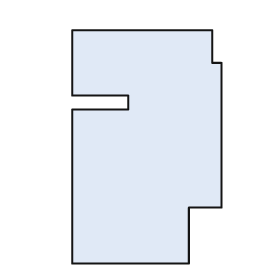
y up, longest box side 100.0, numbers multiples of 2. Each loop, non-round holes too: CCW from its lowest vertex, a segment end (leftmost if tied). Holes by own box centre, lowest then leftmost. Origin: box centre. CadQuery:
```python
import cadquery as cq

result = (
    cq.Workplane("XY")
    .moveTo(-32.0, -50.0)
    .lineTo(18.0, -50.0)
    .lineTo(18.0, -26.0)
    .lineTo(32.0, -26.0)
    .lineTo(32.0, 36.0)
    .lineTo(28.0, 36.0)
    .lineTo(28.0, 50.0)
    .lineTo(-32.0, 50.0)
    .lineTo(-32.0, 22.0)
    .lineTo(-8.0, 22.0)
    .lineTo(-8.0, 16.0)
    .lineTo(-32.0, 16.0)
    .close()
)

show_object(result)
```